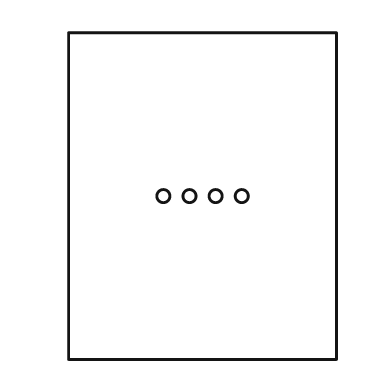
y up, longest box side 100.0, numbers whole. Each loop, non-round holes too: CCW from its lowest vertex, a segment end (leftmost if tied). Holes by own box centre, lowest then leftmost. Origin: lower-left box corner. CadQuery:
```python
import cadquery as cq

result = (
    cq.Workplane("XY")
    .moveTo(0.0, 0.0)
    .lineTo(82.0, 0.0)
    .lineTo(82.0, 100.0)
    .lineTo(0.0, 100.0)
    .close()
    .moveTo(29.0, 50.0)
    .circle(2.0)
    .moveTo(37.0, 50.0)
    .circle(2.0)
    .moveTo(45.0, 50.0)
    .circle(2.0)
    .moveTo(53.0, 50.0)
    .circle(2.0)
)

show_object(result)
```